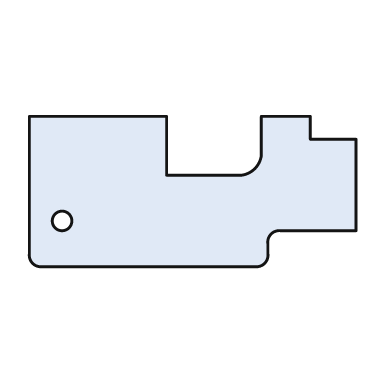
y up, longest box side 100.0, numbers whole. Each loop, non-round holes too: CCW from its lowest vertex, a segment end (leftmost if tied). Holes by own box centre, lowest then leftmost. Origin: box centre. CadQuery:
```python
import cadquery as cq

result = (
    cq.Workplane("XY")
    .moveTo(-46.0, -23.0)
    .lineTo(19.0, -23.0)
    .threePointArc((22.0, -22.0), (23.0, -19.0))
    .lineTo(23.0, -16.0)
    .threePointArc((24.0, -13.0), (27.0, -12.0))
    .lineTo(50.0, -12.0)
    .lineTo(50.0, 16.0)
    .lineTo(36.0, 16.0)
    .lineTo(36.0, 23.0)
    .lineTo(21.0, 23.0)
    .lineTo(21.0, 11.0)
    .threePointArc((19.0, 7.0), (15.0, 5.0))
    .lineTo(-8.0, 5.0)
    .lineTo(-8.0, 23.0)
    .lineTo(-50.0, 23.0)
    .lineTo(-50.0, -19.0)
    .threePointArc((-49.0, -22.0), (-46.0, -23.0))
    .close()
    .moveTo(-40.0, -9.0)
    .circle(3.0)
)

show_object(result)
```